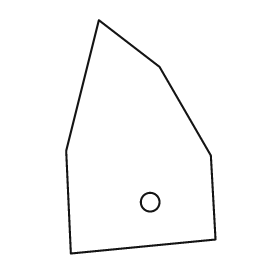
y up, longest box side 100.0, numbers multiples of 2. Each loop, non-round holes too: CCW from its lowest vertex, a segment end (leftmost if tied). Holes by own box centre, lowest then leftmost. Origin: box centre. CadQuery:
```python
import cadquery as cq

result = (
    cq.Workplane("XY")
    .moveTo(-30.0, -50.0)
    .lineTo(32.0, -44.0)
    .lineTo(30.0, -8.0)
    .lineTo(8.0, 30.0)
    .lineTo(-18.0, 50.0)
    .lineTo(-32.0, -6.0)
    .close()
    .moveTo(4.0, -28.0)
    .circle(4.0)
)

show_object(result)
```